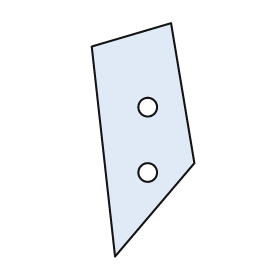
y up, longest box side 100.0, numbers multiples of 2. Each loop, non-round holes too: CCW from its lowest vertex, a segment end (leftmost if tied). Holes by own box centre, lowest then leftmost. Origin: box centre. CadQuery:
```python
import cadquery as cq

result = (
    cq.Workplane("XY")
    .moveTo(-12.0, -50.0)
    .lineTo(22.0, -10.0)
    .lineTo(12.0, 50.0)
    .lineTo(-22.0, 40.0)
    .close()
    .moveTo(2.0, -14.0)
    .circle(4.0)
    .moveTo(2.0, 14.0)
    .circle(4.0)
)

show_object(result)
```